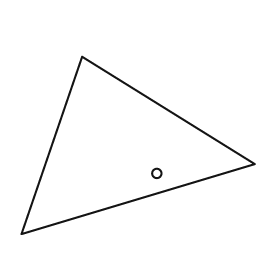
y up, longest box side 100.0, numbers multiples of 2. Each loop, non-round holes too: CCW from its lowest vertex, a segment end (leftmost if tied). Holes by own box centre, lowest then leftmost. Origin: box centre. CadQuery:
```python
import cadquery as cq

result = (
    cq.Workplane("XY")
    .moveTo(-50.0, -38.0)
    .lineTo(50.0, -8.0)
    .lineTo(-24.0, 38.0)
    .close()
    .moveTo(8.0, -12.0)
    .circle(2.0)
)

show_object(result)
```